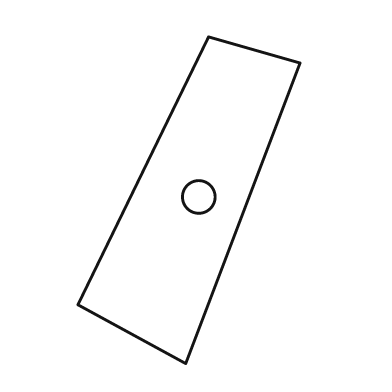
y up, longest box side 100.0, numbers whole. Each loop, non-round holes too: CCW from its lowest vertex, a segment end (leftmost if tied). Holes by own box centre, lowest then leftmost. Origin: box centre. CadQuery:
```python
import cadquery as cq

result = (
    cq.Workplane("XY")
    .moveTo(-1.0, -50.0)
    .lineTo(34.0, 42.0)
    .lineTo(6.0, 50.0)
    .lineTo(-34.0, -32.0)
    .close()
    .moveTo(3.0, 1.0)
    .circle(5.0)
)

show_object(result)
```